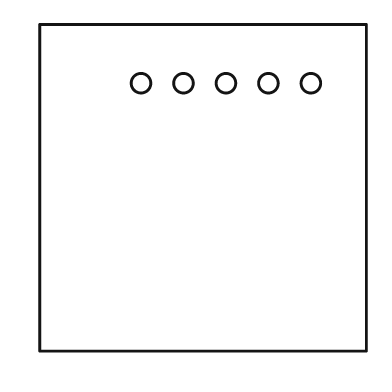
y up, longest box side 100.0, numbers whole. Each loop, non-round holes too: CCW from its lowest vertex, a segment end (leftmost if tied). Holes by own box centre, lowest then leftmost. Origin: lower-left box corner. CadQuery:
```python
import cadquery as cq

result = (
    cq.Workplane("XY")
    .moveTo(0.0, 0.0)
    .lineTo(100.0, 0.0)
    .lineTo(100.0, 100.0)
    .lineTo(0.0, 100.0)
    .close()
    .moveTo(31.0, 82.0)
    .circle(3.0)
    .moveTo(44.0, 82.0)
    .circle(3.0)
    .moveTo(57.0, 82.0)
    .circle(3.0)
    .moveTo(70.0, 82.0)
    .circle(3.0)
    .moveTo(83.0, 82.0)
    .circle(3.0)
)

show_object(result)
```